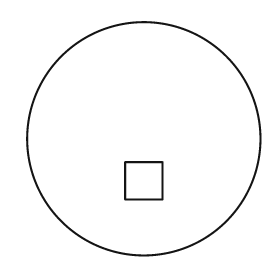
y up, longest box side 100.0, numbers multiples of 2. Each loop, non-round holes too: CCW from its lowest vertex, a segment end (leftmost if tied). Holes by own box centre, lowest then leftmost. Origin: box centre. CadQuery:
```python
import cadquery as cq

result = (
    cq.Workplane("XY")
    .moveTo(0.0, 0.0)
    .circle(50.0)
    .moveTo(-8.0, -26.0)
    .lineTo(8.0, -26.0)
    .lineTo(8.0, -10.0)
    .lineTo(-8.0, -10.0)
    .close()
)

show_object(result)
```